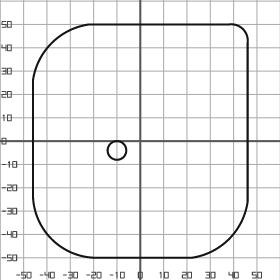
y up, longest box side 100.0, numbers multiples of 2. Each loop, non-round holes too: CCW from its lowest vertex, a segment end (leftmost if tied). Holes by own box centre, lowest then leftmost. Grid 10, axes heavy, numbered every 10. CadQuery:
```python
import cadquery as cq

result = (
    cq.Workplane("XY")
    .moveTo(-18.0, -50.0)
    .lineTo(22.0, -50.0)
    .threePointArc((38.0, -42.0), (46.0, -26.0))
    .lineTo(46.0, 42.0)
    .threePointArc((44.0, 48.0), (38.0, 50.0))
    .lineTo(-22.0, 50.0)
    .threePointArc((-38.0, 42.0), (-46.0, 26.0))
    .lineTo(-46.0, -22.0)
    .threePointArc((-38.0, -42.0), (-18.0, -50.0))
    .close()
    .moveTo(-10.0, -4.0)
    .circle(4.0)
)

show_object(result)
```